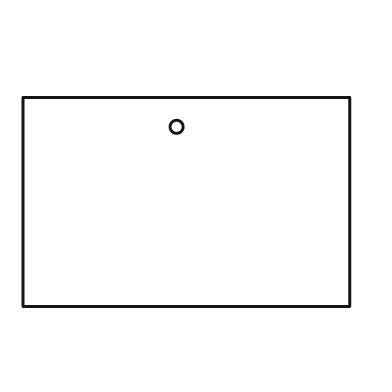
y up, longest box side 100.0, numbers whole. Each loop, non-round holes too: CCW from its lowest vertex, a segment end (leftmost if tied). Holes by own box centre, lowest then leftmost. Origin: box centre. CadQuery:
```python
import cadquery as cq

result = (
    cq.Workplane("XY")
    .moveTo(-50.0, -32.0)
    .lineTo(50.0, -32.0)
    .lineTo(50.0, 32.0)
    .lineTo(-50.0, 32.0)
    .close()
    .moveTo(-3.0, 23.0)
    .circle(2.0)
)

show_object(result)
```